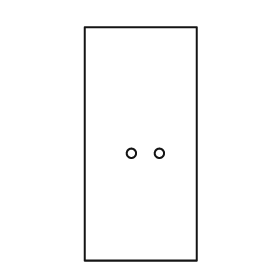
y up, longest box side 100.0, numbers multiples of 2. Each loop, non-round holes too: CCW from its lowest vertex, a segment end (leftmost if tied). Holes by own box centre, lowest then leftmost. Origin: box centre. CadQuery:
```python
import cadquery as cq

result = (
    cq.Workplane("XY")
    .moveTo(-24.0, -50.0)
    .lineTo(24.0, -50.0)
    .lineTo(24.0, 50.0)
    .lineTo(-24.0, 50.0)
    .close()
    .moveTo(-4.0, -4.0)
    .circle(2.0)
    .moveTo(8.0, -4.0)
    .circle(2.0)
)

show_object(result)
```